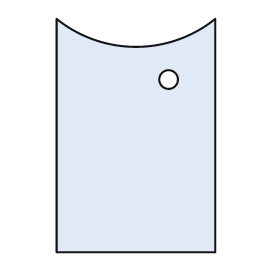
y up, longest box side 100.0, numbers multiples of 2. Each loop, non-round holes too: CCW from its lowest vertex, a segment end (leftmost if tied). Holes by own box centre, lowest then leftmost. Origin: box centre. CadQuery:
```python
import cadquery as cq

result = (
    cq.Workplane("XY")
    .moveTo(-34.0, -50.0)
    .lineTo(34.0, -50.0)
    .lineTo(34.0, 50.0)
    .threePointArc((0.0, 38.0), (-34.0, 50.0))
    .close()
    .moveTo(14.0, 24.0)
    .circle(4.0)
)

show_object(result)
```